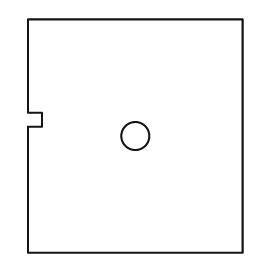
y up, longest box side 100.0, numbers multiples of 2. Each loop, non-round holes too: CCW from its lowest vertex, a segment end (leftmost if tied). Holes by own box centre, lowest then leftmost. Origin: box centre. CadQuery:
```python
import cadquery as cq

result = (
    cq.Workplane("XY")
    .moveTo(-46.0, -50.0)
    .lineTo(46.0, -50.0)
    .lineTo(46.0, 50.0)
    .lineTo(-46.0, 50.0)
    .lineTo(-46.0, 10.0)
    .lineTo(-40.0, 10.0)
    .lineTo(-40.0, 4.0)
    .lineTo(-46.0, 4.0)
    .close()
    .moveTo(0.0, 0.0)
    .circle(6.0)
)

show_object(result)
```